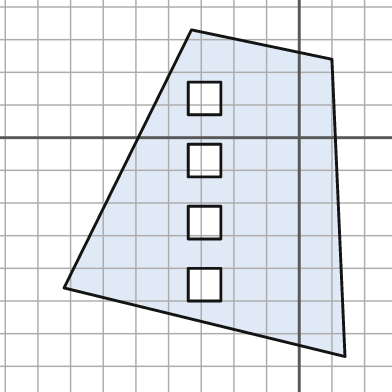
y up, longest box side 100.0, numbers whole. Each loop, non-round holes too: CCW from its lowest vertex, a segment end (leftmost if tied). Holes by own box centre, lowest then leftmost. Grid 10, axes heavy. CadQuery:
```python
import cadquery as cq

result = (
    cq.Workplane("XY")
    .moveTo(14.0, -67.0)
    .lineTo(10.0, 24.0)
    .lineTo(-33.0, 33.0)
    .lineTo(-72.0, -46.0)
    .close()
    .moveTo(-34.0, -50.0)
    .lineTo(-24.0, -50.0)
    .lineTo(-24.0, -40.0)
    .lineTo(-34.0, -40.0)
    .close()
    .moveTo(-34.0, -31.0)
    .lineTo(-24.0, -31.0)
    .lineTo(-24.0, -21.0)
    .lineTo(-34.0, -21.0)
    .close()
    .moveTo(-34.0, -12.0)
    .lineTo(-24.0, -12.0)
    .lineTo(-24.0, -2.0)
    .lineTo(-34.0, -2.0)
    .close()
    .moveTo(-34.0, 7.0)
    .lineTo(-24.0, 7.0)
    .lineTo(-24.0, 17.0)
    .lineTo(-34.0, 17.0)
    .close()
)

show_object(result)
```